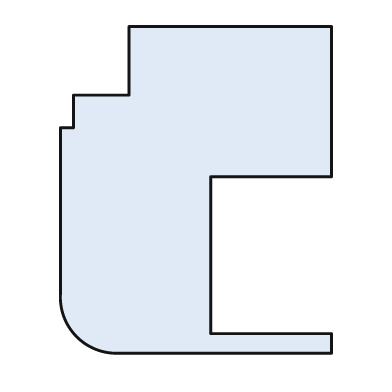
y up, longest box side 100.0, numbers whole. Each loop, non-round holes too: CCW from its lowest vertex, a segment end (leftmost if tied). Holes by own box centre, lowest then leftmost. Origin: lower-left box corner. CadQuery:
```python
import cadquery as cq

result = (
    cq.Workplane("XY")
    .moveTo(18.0, 0.0)
    .lineTo(83.0, 0.0)
    .lineTo(83.0, 6.0)
    .lineTo(46.0, 6.0)
    .lineTo(46.0, 54.0)
    .lineTo(83.0, 54.0)
    .lineTo(83.0, 100.0)
    .lineTo(21.0, 100.0)
    .lineTo(21.0, 79.0)
    .lineTo(4.0, 79.0)
    .lineTo(4.0, 69.0)
    .lineTo(0.0, 69.0)
    .lineTo(0.0, 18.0)
    .threePointArc((5.0, 5.0), (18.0, 0.0))
    .close()
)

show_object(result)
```